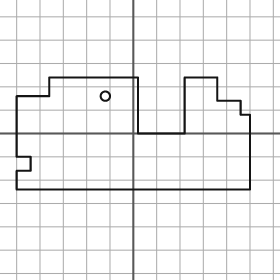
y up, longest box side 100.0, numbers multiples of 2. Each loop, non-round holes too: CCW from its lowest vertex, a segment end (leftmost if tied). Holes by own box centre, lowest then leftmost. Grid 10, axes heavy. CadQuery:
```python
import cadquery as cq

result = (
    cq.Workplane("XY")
    .moveTo(-50.0, -24.0)
    .lineTo(50.0, -24.0)
    .lineTo(50.0, 8.0)
    .lineTo(46.0, 8.0)
    .lineTo(46.0, 14.0)
    .lineTo(36.0, 14.0)
    .lineTo(36.0, 24.0)
    .lineTo(22.0, 24.0)
    .lineTo(22.0, 0.0)
    .lineTo(2.0, 0.0)
    .lineTo(2.0, 24.0)
    .lineTo(-36.0, 24.0)
    .lineTo(-36.0, 16.0)
    .lineTo(-50.0, 16.0)
    .lineTo(-50.0, -10.0)
    .lineTo(-44.0, -10.0)
    .lineTo(-44.0, -16.0)
    .lineTo(-50.0, -16.0)
    .close()
    .moveTo(-12.0, 16.0)
    .circle(2.0)
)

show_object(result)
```